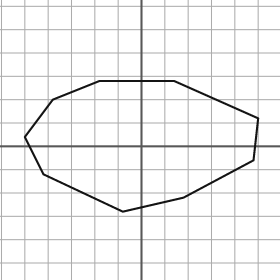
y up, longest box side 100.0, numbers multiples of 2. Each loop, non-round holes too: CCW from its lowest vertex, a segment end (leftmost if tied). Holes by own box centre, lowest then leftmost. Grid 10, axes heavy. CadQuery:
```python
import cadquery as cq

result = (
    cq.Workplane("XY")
    .moveTo(-8.0, -28.0)
    .lineTo(18.0, -22.0)
    .lineTo(48.0, -6.0)
    .lineTo(50.0, 12.0)
    .lineTo(14.0, 28.0)
    .lineTo(-18.0, 28.0)
    .lineTo(-38.0, 20.0)
    .lineTo(-50.0, 4.0)
    .lineTo(-42.0, -12.0)
    .close()
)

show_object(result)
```